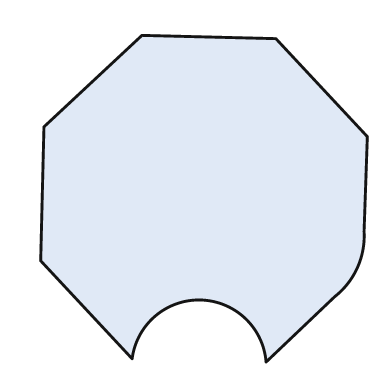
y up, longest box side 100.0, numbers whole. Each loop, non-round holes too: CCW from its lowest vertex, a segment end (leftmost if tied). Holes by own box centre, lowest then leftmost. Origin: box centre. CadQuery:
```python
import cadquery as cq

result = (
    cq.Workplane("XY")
    .moveTo(19.0, -50.0)
    .lineTo(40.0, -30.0)
    .threePointArc((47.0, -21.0), (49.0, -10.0))
    .lineTo(50.0, 19.0)
    .lineTo(22.0, 49.0)
    .lineTo(-19.0, 50.0)
    .lineTo(-49.0, 22.0)
    .lineTo(-50.0, -19.0)
    .lineTo(-22.0, -49.0)
    .threePointArc((-1.0, -31.0), (19.0, -50.0))
    .close()
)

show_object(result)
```